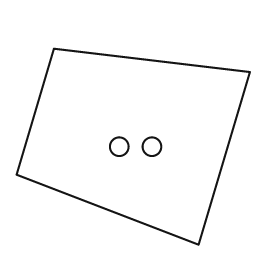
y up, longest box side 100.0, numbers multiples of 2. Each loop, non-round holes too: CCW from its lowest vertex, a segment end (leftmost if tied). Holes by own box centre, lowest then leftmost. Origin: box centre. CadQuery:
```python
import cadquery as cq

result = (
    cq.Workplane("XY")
    .moveTo(28.0, -42.0)
    .lineTo(50.0, 32.0)
    .lineTo(-34.0, 42.0)
    .lineTo(-50.0, -12.0)
    .close()
    .moveTo(-6.0, 0.0)
    .circle(4.0)
    .moveTo(8.0, 0.0)
    .circle(4.0)
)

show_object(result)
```